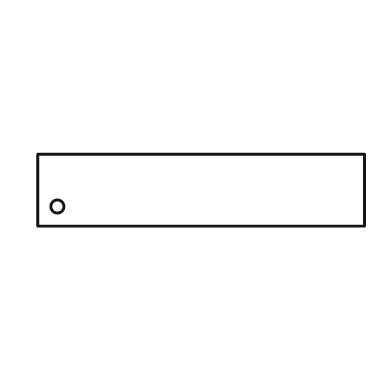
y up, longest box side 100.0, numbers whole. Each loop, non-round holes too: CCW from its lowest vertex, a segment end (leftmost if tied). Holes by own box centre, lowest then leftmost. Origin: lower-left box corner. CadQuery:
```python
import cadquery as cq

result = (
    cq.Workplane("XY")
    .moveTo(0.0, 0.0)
    .lineTo(100.0, 0.0)
    .lineTo(100.0, 22.0)
    .lineTo(0.0, 22.0)
    .close()
    .moveTo(6.0, 6.0)
    .circle(2.0)
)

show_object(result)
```